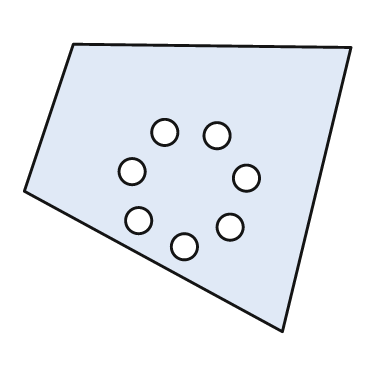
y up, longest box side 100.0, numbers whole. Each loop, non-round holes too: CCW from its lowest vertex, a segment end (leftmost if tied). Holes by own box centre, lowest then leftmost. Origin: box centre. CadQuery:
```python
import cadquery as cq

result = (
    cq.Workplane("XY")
    .moveTo(29.0, -44.0)
    .lineTo(50.0, 43.0)
    .lineTo(-35.0, 44.0)
    .lineTo(-50.0, -1.0)
    .close()
    .moveTo(-1.0, -18.0)
    .circle(4.0)
    .moveTo(13.0, -12.0)
    .circle(4.0)
    .moveTo(-15.0, -10.0)
    .circle(4.0)
    .moveTo(18.0, 3.0)
    .circle(4.0)
    .moveTo(-17.0, 5.0)
    .circle(4.0)
    .moveTo(9.0, 16.0)
    .circle(4.0)
    .moveTo(-7.0, 17.0)
    .circle(4.0)
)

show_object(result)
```